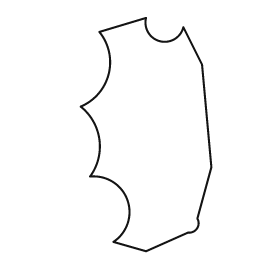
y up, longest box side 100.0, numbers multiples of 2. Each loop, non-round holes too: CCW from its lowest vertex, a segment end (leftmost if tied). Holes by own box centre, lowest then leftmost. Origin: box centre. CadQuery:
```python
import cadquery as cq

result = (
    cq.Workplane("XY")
    .moveTo(0.0, -50.0)
    .lineTo(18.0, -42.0)
    .threePointArc((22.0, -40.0), (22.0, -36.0))
    .lineTo(28.0, -14.0)
    .lineTo(24.0, 30.0)
    .lineTo(16.0, 46.0)
    .threePointArc((6.0, 40.0), (0.0, 50.0))
    .lineTo(-20.0, 44.0)
    .threePointArc((-16.0, 26.0), (-28.0, 12.0))
    .threePointArc((-20.0, -2.0), (-24.0, -18.0))
    .threePointArc((-8.0, -28.0), (-14.0, -46.0))
    .close()
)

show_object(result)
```